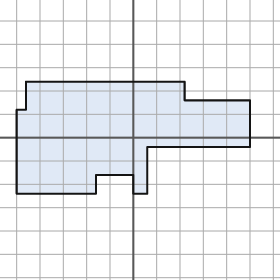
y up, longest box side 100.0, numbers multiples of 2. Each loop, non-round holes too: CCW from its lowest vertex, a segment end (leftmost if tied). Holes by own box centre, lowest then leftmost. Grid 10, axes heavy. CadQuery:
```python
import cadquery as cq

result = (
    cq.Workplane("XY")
    .moveTo(-50.0, -24.0)
    .lineTo(-16.0, -24.0)
    .lineTo(-16.0, -16.0)
    .lineTo(0.0, -16.0)
    .lineTo(0.0, -24.0)
    .lineTo(6.0, -24.0)
    .lineTo(6.0, -4.0)
    .lineTo(50.0, -4.0)
    .lineTo(50.0, 16.0)
    .lineTo(22.0, 16.0)
    .lineTo(22.0, 24.0)
    .lineTo(-46.0, 24.0)
    .lineTo(-46.0, 12.0)
    .lineTo(-50.0, 12.0)
    .close()
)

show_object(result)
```